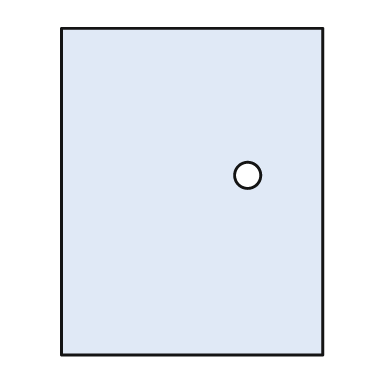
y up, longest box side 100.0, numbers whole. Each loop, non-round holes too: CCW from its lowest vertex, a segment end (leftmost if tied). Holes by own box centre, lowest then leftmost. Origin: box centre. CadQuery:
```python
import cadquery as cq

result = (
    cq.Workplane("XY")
    .moveTo(-40.0, -50.0)
    .lineTo(40.0, -50.0)
    .lineTo(40.0, 50.0)
    .lineTo(-40.0, 50.0)
    .close()
    .moveTo(17.0, 5.0)
    .circle(4.0)
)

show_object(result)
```